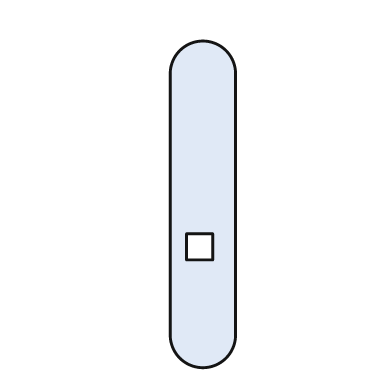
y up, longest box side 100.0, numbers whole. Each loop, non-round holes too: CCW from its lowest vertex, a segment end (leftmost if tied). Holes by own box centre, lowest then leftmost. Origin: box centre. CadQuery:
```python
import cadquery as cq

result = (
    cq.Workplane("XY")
    .moveTo(-10.0, -40.0)
    .threePointArc((0.0, -50.0), (10.0, -40.0))
    .lineTo(10.0, 40.0)
    .threePointArc((0.0, 50.0), (-10.0, 40.0))
    .close()
    .moveTo(-5.0, -17.0)
    .lineTo(3.0, -17.0)
    .lineTo(3.0, -9.0)
    .lineTo(-5.0, -9.0)
    .close()
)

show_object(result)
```